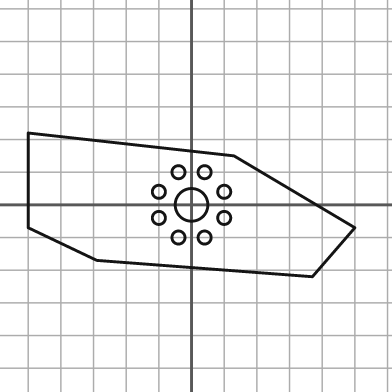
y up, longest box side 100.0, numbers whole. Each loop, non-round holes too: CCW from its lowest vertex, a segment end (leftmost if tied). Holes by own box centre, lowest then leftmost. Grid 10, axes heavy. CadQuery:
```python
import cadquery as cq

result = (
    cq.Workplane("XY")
    .moveTo(37.0, -22.0)
    .lineTo(50.0, -7.0)
    .lineTo(13.0, 15.0)
    .lineTo(-50.0, 22.0)
    .lineTo(-50.0, -7.0)
    .lineTo(-29.0, -17.0)
    .close()
    .moveTo(-4.0, -10.0)
    .circle(2.0)
    .moveTo(4.0, -10.0)
    .circle(2.0)
    .moveTo(-10.0, -4.0)
    .circle(2.0)
    .moveTo(10.0, -4.0)
    .circle(2.0)
    .moveTo(0.0, 0.0)
    .circle(5.0)
    .moveTo(-10.0, 4.0)
    .circle(2.0)
    .moveTo(10.0, 4.0)
    .circle(2.0)
    .moveTo(-4.0, 10.0)
    .circle(2.0)
    .moveTo(4.0, 10.0)
    .circle(2.0)
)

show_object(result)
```